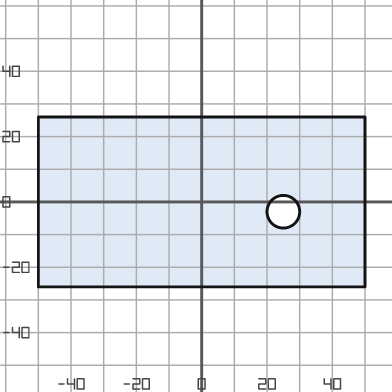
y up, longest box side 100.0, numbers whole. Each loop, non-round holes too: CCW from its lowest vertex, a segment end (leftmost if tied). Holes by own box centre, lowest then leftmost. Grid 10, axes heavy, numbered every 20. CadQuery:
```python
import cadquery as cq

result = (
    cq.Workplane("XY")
    .moveTo(-50.0, -26.0)
    .lineTo(50.0, -26.0)
    .lineTo(50.0, 26.0)
    .lineTo(-50.0, 26.0)
    .close()
    .moveTo(25.0, -3.0)
    .circle(5.0)
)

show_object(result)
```